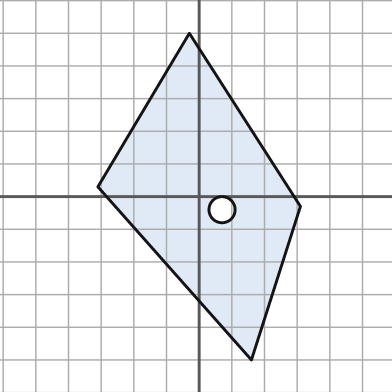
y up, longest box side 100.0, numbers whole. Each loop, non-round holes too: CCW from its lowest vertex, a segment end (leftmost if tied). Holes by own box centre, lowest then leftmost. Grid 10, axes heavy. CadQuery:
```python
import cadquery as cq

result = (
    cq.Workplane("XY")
    .moveTo(16.0, -50.0)
    .lineTo(31.0, -3.0)
    .lineTo(-3.0, 50.0)
    .lineTo(-31.0, 3.0)
    .close()
    .moveTo(7.0, -4.0)
    .circle(4.0)
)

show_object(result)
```